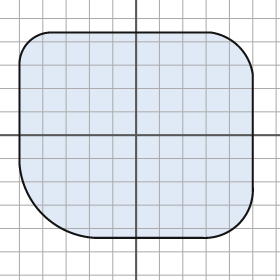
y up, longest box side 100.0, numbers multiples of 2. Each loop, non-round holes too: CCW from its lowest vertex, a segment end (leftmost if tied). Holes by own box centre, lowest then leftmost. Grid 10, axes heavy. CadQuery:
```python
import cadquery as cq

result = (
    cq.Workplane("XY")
    .moveTo(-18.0, -44.0)
    .lineTo(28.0, -44.0)
    .threePointArc((44.0, -38.0), (50.0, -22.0))
    .lineTo(50.0, 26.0)
    .threePointArc((44.0, 38.0), (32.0, 44.0))
    .lineTo(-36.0, 44.0)
    .threePointArc((-46.0, 40.0), (-50.0, 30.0))
    .lineTo(-50.0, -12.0)
    .threePointArc((-40.0, -34.0), (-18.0, -44.0))
    .close()
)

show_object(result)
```